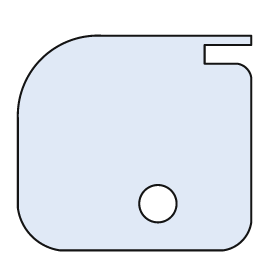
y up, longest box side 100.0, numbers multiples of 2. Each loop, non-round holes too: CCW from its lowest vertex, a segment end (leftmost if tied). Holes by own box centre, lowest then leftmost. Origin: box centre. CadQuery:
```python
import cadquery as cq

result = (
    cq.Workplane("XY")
    .moveTo(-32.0, -46.0)
    .lineTo(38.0, -46.0)
    .threePointArc((46.0, -42.0), (50.0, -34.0))
    .lineTo(50.0, 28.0)
    .threePointArc((48.0, 32.0), (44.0, 34.0))
    .lineTo(30.0, 34.0)
    .lineTo(30.0, 42.0)
    .lineTo(50.0, 42.0)
    .lineTo(50.0, 46.0)
    .lineTo(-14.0, 46.0)
    .threePointArc((-40.0, 36.0), (-50.0, 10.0))
    .lineTo(-50.0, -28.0)
    .threePointArc((-44.0, -40.0), (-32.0, -46.0))
    .close()
    .moveTo(10.0, -26.0)
    .circle(8.0)
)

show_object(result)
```